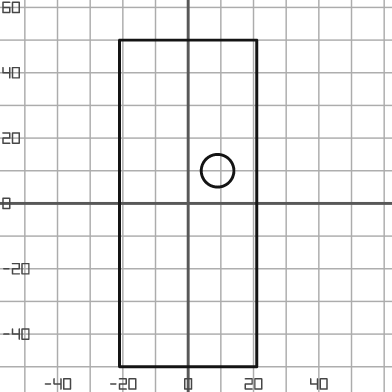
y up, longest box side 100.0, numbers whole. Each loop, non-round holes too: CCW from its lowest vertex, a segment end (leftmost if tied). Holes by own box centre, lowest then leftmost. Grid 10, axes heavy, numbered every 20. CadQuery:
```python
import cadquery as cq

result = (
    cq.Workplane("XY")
    .moveTo(-21.0, -50.0)
    .lineTo(21.0, -50.0)
    .lineTo(21.0, 50.0)
    .lineTo(-21.0, 50.0)
    .close()
    .moveTo(9.0, 10.0)
    .circle(5.0)
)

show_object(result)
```